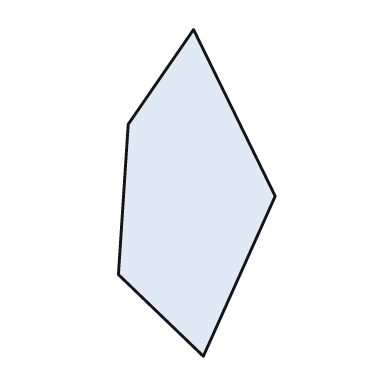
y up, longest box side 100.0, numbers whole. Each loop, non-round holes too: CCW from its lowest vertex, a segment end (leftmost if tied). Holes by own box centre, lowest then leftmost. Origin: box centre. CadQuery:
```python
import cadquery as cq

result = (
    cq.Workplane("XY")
    .moveTo(2.0, -50.0)
    .lineTo(24.0, -1.0)
    .lineTo(-1.0, 50.0)
    .lineTo(-21.0, 21.0)
    .lineTo(-24.0, -25.0)
    .close()
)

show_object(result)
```